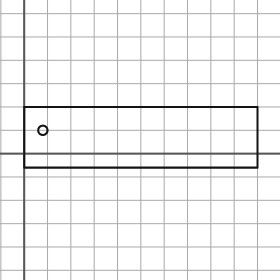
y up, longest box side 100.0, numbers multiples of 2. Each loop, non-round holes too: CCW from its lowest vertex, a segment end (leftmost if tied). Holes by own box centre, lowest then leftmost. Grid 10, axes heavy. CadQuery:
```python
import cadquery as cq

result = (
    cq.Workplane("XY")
    .moveTo(0.0, -6.0)
    .lineTo(100.0, -6.0)
    .lineTo(100.0, 20.0)
    .lineTo(0.0, 20.0)
    .close()
    .moveTo(8.0, 10.0)
    .circle(2.0)
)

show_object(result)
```